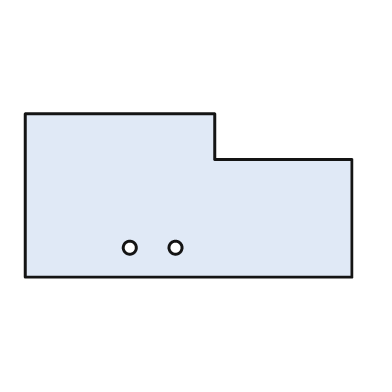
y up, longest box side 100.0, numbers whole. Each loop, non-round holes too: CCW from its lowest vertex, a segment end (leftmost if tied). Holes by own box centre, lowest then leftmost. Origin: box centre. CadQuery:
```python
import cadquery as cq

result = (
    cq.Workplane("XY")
    .moveTo(-50.0, -25.0)
    .lineTo(50.0, -25.0)
    .lineTo(50.0, 11.0)
    .lineTo(8.0, 11.0)
    .lineTo(8.0, 25.0)
    .lineTo(-50.0, 25.0)
    .close()
    .moveTo(-18.0, -16.0)
    .circle(2.0)
    .moveTo(-4.0, -16.0)
    .circle(2.0)
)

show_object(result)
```